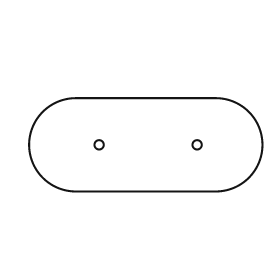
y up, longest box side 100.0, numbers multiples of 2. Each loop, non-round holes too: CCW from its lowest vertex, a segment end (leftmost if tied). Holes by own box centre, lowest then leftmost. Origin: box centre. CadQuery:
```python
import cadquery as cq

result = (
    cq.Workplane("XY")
    .moveTo(-30.0, -20.0)
    .lineTo(30.0, -20.0)
    .threePointArc((50.0, 0.0), (30.0, 20.0))
    .lineTo(-30.0, 20.0)
    .threePointArc((-50.0, 0.0), (-30.0, -20.0))
    .close()
    .moveTo(-20.0, 0.0)
    .circle(2.0)
    .moveTo(22.0, 0.0)
    .circle(2.0)
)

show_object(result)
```